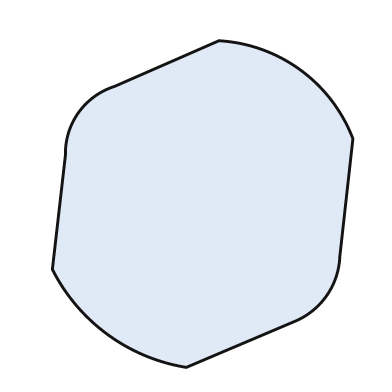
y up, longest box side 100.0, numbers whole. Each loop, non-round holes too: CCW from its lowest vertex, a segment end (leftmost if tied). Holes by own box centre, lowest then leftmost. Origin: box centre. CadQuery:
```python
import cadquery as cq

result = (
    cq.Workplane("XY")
    .moveTo(-5.0, -50.0)
    .lineTo(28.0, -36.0)
    .threePointArc((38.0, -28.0), (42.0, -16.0))
    .lineTo(46.0, 20.0)
    .threePointArc((30.0, 41.0), (5.0, 50.0))
    .lineTo(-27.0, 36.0)
    .threePointArc((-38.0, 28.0), (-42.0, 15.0))
    .lineTo(-46.0, -20.0)
    .threePointArc((-29.0, -40.0), (-5.0, -50.0))
    .close()
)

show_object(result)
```